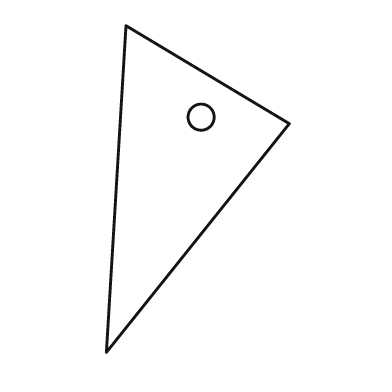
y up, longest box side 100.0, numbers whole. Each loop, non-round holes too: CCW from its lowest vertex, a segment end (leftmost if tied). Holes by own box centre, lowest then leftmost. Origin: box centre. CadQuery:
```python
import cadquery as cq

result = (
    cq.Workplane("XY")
    .moveTo(-28.0, -50.0)
    .lineTo(28.0, 20.0)
    .lineTo(-22.0, 50.0)
    .close()
    .moveTo(1.0, 22.0)
    .circle(4.0)
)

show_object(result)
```